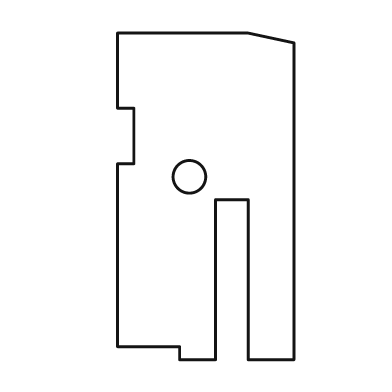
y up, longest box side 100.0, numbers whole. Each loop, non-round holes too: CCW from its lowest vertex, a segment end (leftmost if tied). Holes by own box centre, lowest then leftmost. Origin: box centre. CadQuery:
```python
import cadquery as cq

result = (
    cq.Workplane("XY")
    .moveTo(-8.0, -50.0)
    .lineTo(3.0, -50.0)
    .lineTo(3.0, -1.0)
    .lineTo(13.0, -1.0)
    .lineTo(13.0, -50.0)
    .lineTo(27.0, -50.0)
    .lineTo(27.0, 47.0)
    .lineTo(13.0, 50.0)
    .lineTo(-27.0, 50.0)
    .lineTo(-27.0, 27.0)
    .lineTo(-22.0, 27.0)
    .lineTo(-22.0, 10.0)
    .lineTo(-27.0, 10.0)
    .lineTo(-27.0, -46.0)
    .lineTo(-8.0, -46.0)
    .close()
    .moveTo(-5.0, 6.0)
    .circle(5.0)
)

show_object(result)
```